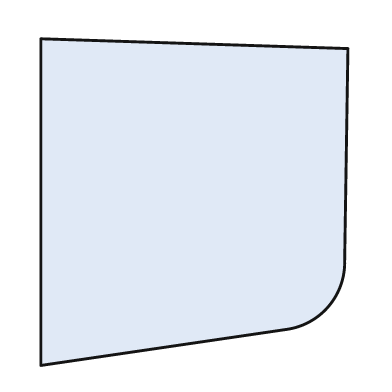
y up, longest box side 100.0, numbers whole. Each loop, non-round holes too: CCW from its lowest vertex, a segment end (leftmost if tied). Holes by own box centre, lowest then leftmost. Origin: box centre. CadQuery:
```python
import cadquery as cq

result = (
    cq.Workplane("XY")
    .moveTo(-47.0, -50.0)
    .lineTo(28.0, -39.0)
    .threePointArc((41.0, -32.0), (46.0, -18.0))
    .lineTo(47.0, 47.0)
    .lineTo(-47.0, 50.0)
    .close()
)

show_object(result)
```